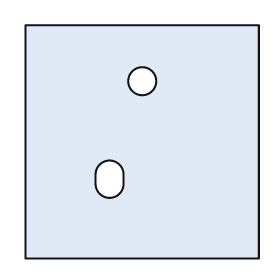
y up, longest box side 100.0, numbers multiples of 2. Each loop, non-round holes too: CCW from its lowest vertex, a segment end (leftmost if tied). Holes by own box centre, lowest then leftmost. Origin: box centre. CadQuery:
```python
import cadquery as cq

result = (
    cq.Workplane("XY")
    .moveTo(-50.0, -50.0)
    .lineTo(50.0, -50.0)
    .lineTo(50.0, 50.0)
    .lineTo(-50.0, 50.0)
    .close()
    .moveTo(-20.0, -18.0)
    .threePointArc((-14.0, -24.0), (-8.0, -18.0))
    .lineTo(-8.0, -14.0)
    .threePointArc((-14.0, -8.0), (-20.0, -14.0))
    .close()
    .moveTo(0.0, 26.0)
    .circle(6.0)
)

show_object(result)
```